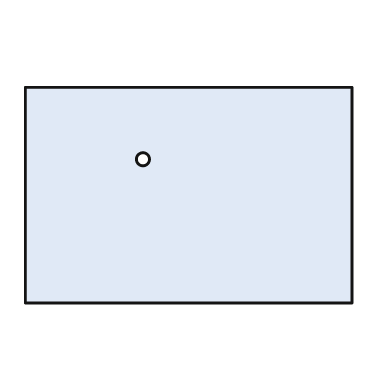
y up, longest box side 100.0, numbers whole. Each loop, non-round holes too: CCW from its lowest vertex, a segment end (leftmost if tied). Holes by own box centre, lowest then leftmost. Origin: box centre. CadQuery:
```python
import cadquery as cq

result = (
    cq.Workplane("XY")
    .moveTo(-50.0, -33.0)
    .lineTo(50.0, -33.0)
    .lineTo(50.0, 33.0)
    .lineTo(-50.0, 33.0)
    .close()
    .moveTo(-14.0, 11.0)
    .circle(2.0)
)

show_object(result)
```